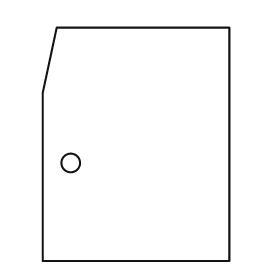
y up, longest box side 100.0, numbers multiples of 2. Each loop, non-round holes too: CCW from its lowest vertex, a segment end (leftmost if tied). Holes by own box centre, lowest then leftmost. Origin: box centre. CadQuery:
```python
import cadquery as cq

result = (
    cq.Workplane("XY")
    .moveTo(-40.0, -50.0)
    .lineTo(40.0, -50.0)
    .lineTo(40.0, 50.0)
    .lineTo(-34.0, 50.0)
    .lineTo(-40.0, 22.0)
    .close()
    .moveTo(-28.0, -8.0)
    .circle(4.0)
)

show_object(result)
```